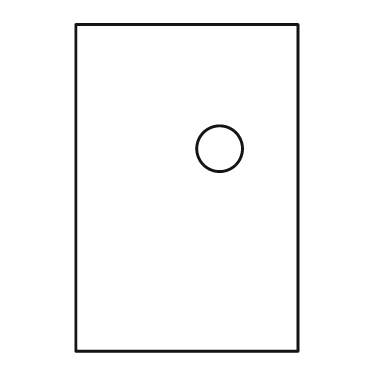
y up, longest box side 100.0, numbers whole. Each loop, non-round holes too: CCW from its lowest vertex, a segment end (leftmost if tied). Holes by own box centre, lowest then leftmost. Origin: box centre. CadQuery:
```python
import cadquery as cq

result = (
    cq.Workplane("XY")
    .moveTo(-34.0, -50.0)
    .lineTo(34.0, -50.0)
    .lineTo(34.0, 50.0)
    .lineTo(-34.0, 50.0)
    .close()
    .moveTo(10.0, 12.0)
    .circle(7.0)
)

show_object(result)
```